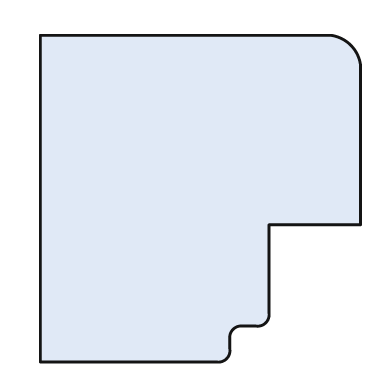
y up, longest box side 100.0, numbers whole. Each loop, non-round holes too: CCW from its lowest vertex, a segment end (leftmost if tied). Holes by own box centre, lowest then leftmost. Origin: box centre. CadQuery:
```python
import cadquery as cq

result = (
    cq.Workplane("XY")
    .moveTo(-49.0, -50.0)
    .lineTo(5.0, -50.0)
    .threePointArc((8.0, -49.0), (9.0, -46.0))
    .lineTo(9.0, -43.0)
    .threePointArc((10.0, -40.0), (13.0, -39.0))
    .lineTo(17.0, -39.0)
    .threePointArc((20.0, -38.0), (21.0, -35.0))
    .lineTo(21.0, -8.0)
    .lineTo(49.0, -8.0)
    .lineTo(49.0, 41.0)
    .threePointArc((46.0, 47.0), (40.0, 50.0))
    .lineTo(-49.0, 50.0)
    .close()
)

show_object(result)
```